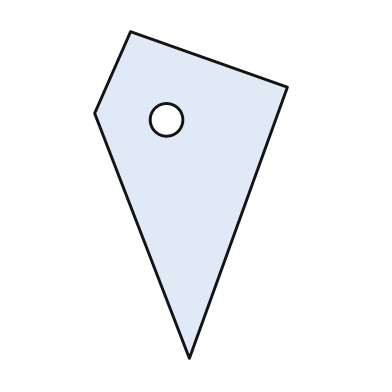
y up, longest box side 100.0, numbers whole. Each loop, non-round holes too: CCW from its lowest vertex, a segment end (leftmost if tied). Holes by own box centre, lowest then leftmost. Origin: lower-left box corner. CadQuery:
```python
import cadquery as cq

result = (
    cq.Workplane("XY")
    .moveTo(29.0, 0.0)
    .lineTo(59.0, 83.0)
    .lineTo(11.0, 100.0)
    .lineTo(0.0, 75.0)
    .close()
    .moveTo(22.0, 73.0)
    .circle(5.0)
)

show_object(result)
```